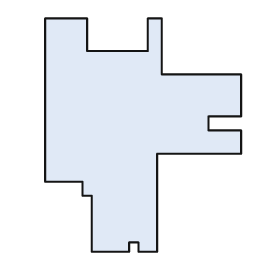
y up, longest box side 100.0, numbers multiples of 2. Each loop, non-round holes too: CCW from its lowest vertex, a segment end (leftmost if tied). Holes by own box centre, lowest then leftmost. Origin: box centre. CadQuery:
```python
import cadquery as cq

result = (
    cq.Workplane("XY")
    .moveTo(-22.0, -50.0)
    .lineTo(-6.0, -50.0)
    .lineTo(-6.0, -46.0)
    .lineTo(-2.0, -46.0)
    .lineTo(-2.0, -50.0)
    .lineTo(6.0, -50.0)
    .lineTo(6.0, -8.0)
    .lineTo(42.0, -8.0)
    .lineTo(42.0, 2.0)
    .lineTo(28.0, 2.0)
    .lineTo(28.0, 8.0)
    .lineTo(42.0, 8.0)
    .lineTo(42.0, 26.0)
    .lineTo(8.0, 26.0)
    .lineTo(8.0, 50.0)
    .lineTo(2.0, 50.0)
    .lineTo(2.0, 36.0)
    .lineTo(-24.0, 36.0)
    .lineTo(-24.0, 50.0)
    .lineTo(-42.0, 50.0)
    .lineTo(-42.0, -20.0)
    .lineTo(-26.0, -20.0)
    .lineTo(-26.0, -26.0)
    .lineTo(-22.0, -26.0)
    .close()
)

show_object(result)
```